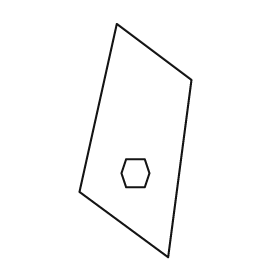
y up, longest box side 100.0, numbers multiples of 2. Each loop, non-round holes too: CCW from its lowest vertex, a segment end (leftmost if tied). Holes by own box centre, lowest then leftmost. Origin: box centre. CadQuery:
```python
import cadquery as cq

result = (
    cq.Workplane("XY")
    .moveTo(14.0, -50.0)
    .lineTo(24.0, 26.0)
    .lineTo(-8.0, 50.0)
    .lineTo(-24.0, -22.0)
    .close()
    .moveTo(-4.0, -20.0)
    .lineTo(4.0, -20.0)
    .lineTo(6.0, -14.0)
    .lineTo(4.0, -8.0)
    .lineTo(-4.0, -8.0)
    .lineTo(-6.0, -14.0)
    .close()
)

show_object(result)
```